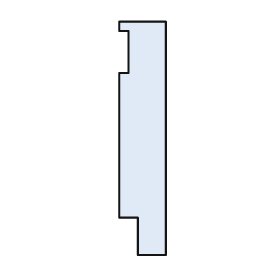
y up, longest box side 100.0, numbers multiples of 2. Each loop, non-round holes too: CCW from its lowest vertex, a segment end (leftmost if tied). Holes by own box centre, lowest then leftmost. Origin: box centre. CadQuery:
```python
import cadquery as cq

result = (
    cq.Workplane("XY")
    .moveTo(-2.0, -50.0)
    .lineTo(10.0, -50.0)
    .lineTo(10.0, 50.0)
    .lineTo(-10.0, 50.0)
    .lineTo(-10.0, 46.0)
    .lineTo(-6.0, 46.0)
    .lineTo(-6.0, 28.0)
    .lineTo(-10.0, 28.0)
    .lineTo(-10.0, -34.0)
    .lineTo(-2.0, -34.0)
    .close()
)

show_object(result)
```